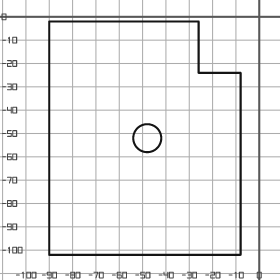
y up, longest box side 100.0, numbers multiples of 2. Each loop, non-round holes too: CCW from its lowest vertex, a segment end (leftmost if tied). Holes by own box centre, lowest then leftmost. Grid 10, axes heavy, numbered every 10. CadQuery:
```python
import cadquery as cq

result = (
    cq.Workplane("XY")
    .moveTo(-90.0, -102.0)
    .lineTo(-8.0, -102.0)
    .lineTo(-8.0, -24.0)
    .lineTo(-26.0, -24.0)
    .lineTo(-26.0, -2.0)
    .lineTo(-90.0, -2.0)
    .close()
    .moveTo(-48.0, -52.0)
    .circle(6.0)
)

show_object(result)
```